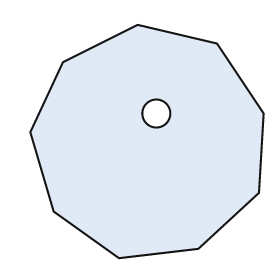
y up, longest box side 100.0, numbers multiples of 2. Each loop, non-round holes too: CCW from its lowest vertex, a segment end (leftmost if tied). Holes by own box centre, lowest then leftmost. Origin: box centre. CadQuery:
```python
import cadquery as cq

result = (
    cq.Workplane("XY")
    .moveTo(-12.0, -50.0)
    .lineTo(22.0, -46.0)
    .lineTo(48.0, -22.0)
    .lineTo(50.0, 12.0)
    .lineTo(30.0, 42.0)
    .lineTo(-4.0, 50.0)
    .lineTo(-36.0, 34.0)
    .lineTo(-50.0, 4.0)
    .lineTo(-40.0, -30.0)
    .close()
    .moveTo(4.0, 12.0)
    .circle(6.0)
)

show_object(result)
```